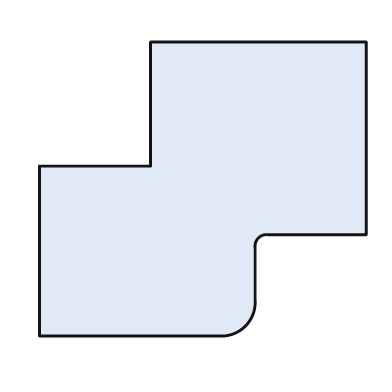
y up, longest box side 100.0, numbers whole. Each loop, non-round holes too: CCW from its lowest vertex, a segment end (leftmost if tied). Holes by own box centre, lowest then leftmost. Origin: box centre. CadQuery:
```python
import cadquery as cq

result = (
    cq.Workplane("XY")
    .moveTo(-50.0, -45.0)
    .lineTo(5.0, -45.0)
    .threePointArc((13.0, -42.0), (16.0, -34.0))
    .lineTo(16.0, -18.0)
    .threePointArc((17.0, -15.0), (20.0, -14.0))
    .lineTo(50.0, -14.0)
    .lineTo(50.0, 45.0)
    .lineTo(-16.0, 45.0)
    .lineTo(-16.0, 7.0)
    .lineTo(-50.0, 7.0)
    .close()
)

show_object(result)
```